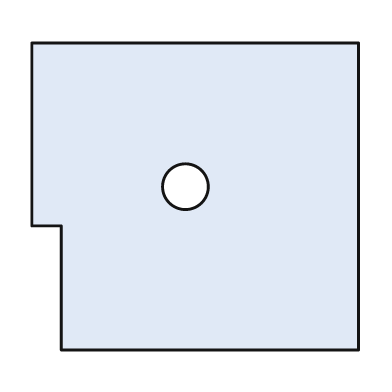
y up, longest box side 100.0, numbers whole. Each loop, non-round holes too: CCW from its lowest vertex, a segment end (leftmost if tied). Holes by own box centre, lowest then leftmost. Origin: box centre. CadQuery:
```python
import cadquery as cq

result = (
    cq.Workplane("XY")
    .moveTo(-41.0, -47.0)
    .lineTo(50.0, -47.0)
    .lineTo(50.0, 47.0)
    .lineTo(-50.0, 47.0)
    .lineTo(-50.0, -9.0)
    .lineTo(-41.0, -9.0)
    .close()
    .moveTo(-3.0, 3.0)
    .circle(7.0)
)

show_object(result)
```